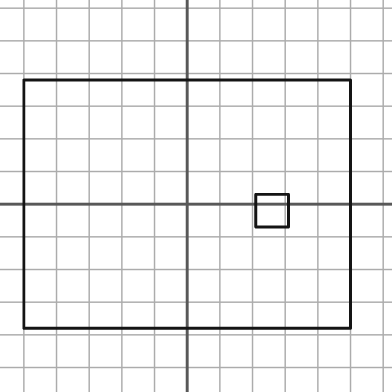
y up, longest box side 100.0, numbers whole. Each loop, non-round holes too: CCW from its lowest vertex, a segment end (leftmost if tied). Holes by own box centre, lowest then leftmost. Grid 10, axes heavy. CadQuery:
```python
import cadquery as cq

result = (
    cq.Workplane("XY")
    .moveTo(-50.0, -38.0)
    .lineTo(50.0, -38.0)
    .lineTo(50.0, 38.0)
    .lineTo(-50.0, 38.0)
    .close()
    .moveTo(21.0, -7.0)
    .lineTo(31.0, -7.0)
    .lineTo(31.0, 3.0)
    .lineTo(21.0, 3.0)
    .close()
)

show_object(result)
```